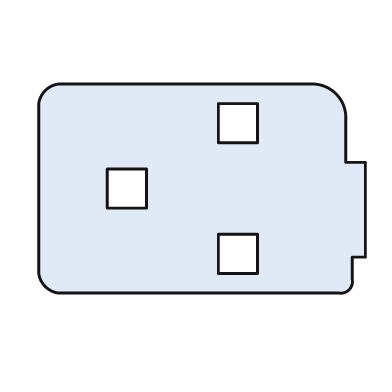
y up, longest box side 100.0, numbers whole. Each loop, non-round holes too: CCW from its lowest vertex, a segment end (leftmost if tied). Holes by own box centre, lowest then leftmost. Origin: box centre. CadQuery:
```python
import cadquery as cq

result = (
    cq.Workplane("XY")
    .moveTo(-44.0, -32.0)
    .lineTo(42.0, -32.0)
    .threePointArc((45.0, -31.0), (46.0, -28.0))
    .lineTo(46.0, -21.0)
    .lineTo(50.0, -21.0)
    .lineTo(50.0, 8.0)
    .lineTo(44.0, 8.0)
    .lineTo(44.0, 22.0)
    .threePointArc((41.0, 29.0), (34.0, 32.0))
    .lineTo(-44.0, 32.0)
    .threePointArc((-48.0, 30.0), (-50.0, 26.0))
    .lineTo(-50.0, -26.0)
    .threePointArc((-48.0, -30.0), (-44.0, -32.0))
    .close()
    .moveTo(5.0, -26.0)
    .lineTo(17.0, -26.0)
    .lineTo(17.0, -14.0)
    .lineTo(5.0, -14.0)
    .close()
    .moveTo(-29.0, -6.0)
    .lineTo(-17.0, -6.0)
    .lineTo(-17.0, 6.0)
    .lineTo(-29.0, 6.0)
    .close()
    .moveTo(5.0, 14.0)
    .lineTo(17.0, 14.0)
    .lineTo(17.0, 26.0)
    .lineTo(5.0, 26.0)
    .close()
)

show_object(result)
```